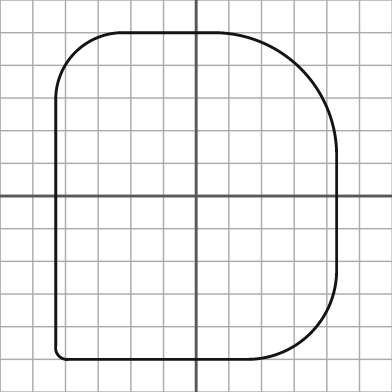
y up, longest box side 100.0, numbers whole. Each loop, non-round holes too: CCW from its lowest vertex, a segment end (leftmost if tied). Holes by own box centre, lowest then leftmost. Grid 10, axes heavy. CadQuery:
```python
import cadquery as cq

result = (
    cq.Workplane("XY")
    .moveTo(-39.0, -50.0)
    .lineTo(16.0, -50.0)
    .threePointArc((35.0, -42.0), (43.0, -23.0))
    .lineTo(43.0, 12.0)
    .threePointArc((32.0, 39.0), (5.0, 50.0))
    .lineTo(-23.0, 50.0)
    .threePointArc((-37.0, 44.0), (-43.0, 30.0))
    .lineTo(-43.0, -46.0)
    .threePointArc((-42.0, -49.0), (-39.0, -50.0))
    .close()
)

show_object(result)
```